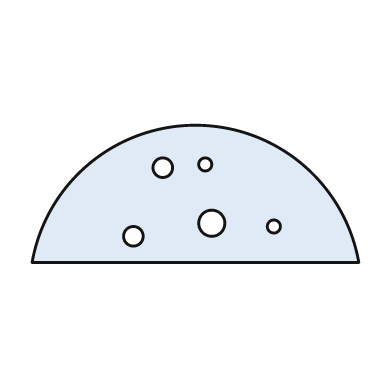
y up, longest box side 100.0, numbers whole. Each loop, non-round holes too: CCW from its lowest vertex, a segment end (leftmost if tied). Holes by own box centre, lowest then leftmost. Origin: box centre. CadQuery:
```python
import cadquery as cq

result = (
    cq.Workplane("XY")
    .moveTo(-50.0, -21.0)
    .lineTo(50.0, -21.0)
    .threePointArc((0.0, 21.0), (-50.0, -21.0))
    .close()
    .moveTo(-19.0, -13.0)
    .circle(3.0)
    .moveTo(24.0, -10.0)
    .circle(2.0)
    .moveTo(5.0, -9.0)
    .circle(4.0)
    .moveTo(-10.0, 8.0)
    .circle(3.0)
    .moveTo(3.0, 9.0)
    .circle(2.0)
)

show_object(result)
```